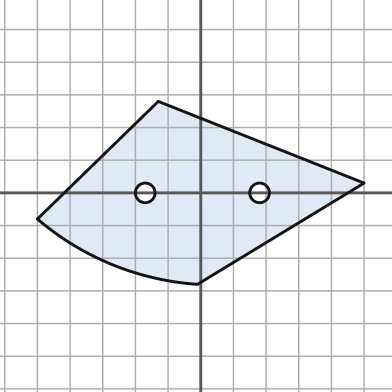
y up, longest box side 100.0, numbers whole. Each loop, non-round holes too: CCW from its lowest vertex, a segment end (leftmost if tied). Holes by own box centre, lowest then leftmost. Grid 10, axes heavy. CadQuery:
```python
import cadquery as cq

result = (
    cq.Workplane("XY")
    .moveTo(-1.0, -28.0)
    .lineTo(50.0, 3.0)
    .lineTo(-13.0, 28.0)
    .lineTo(-50.0, -8.0)
    .threePointArc((-27.0, -22.0), (-1.0, -28.0))
    .close()
    .moveTo(-17.0, 0.0)
    .circle(3.0)
    .moveTo(18.0, 0.0)
    .circle(3.0)
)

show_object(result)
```